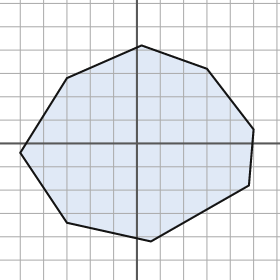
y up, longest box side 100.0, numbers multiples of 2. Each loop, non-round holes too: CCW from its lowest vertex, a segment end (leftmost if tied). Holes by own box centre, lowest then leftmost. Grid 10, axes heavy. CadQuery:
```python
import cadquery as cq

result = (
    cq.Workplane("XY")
    .moveTo(6.0, -42.0)
    .lineTo(48.0, -18.0)
    .lineTo(50.0, 6.0)
    .lineTo(30.0, 32.0)
    .lineTo(2.0, 42.0)
    .lineTo(-30.0, 28.0)
    .lineTo(-50.0, -4.0)
    .lineTo(-30.0, -34.0)
    .close()
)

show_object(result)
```